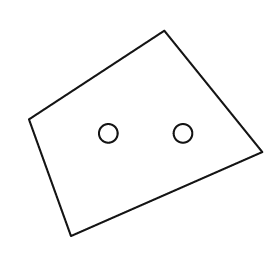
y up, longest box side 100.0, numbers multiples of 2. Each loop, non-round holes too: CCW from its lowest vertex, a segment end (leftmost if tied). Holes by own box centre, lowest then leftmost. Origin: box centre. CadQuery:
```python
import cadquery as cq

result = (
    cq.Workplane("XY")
    .moveTo(-32.0, -44.0)
    .lineTo(50.0, -8.0)
    .lineTo(8.0, 44.0)
    .lineTo(-50.0, 6.0)
    .close()
    .moveTo(-16.0, 0.0)
    .circle(4.0)
    .moveTo(16.0, 0.0)
    .circle(4.0)
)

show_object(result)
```